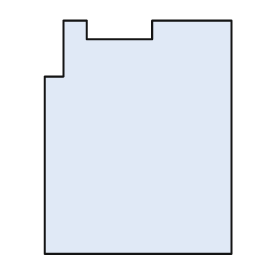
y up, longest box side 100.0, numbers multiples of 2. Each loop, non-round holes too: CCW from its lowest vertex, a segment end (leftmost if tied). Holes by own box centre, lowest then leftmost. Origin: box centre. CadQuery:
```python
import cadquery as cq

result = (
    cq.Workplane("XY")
    .moveTo(-40.0, -50.0)
    .lineTo(40.0, -50.0)
    .lineTo(40.0, 50.0)
    .lineTo(6.0, 50.0)
    .lineTo(6.0, 42.0)
    .lineTo(-22.0, 42.0)
    .lineTo(-22.0, 50.0)
    .lineTo(-32.0, 50.0)
    .lineTo(-32.0, 26.0)
    .lineTo(-40.0, 26.0)
    .close()
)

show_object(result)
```